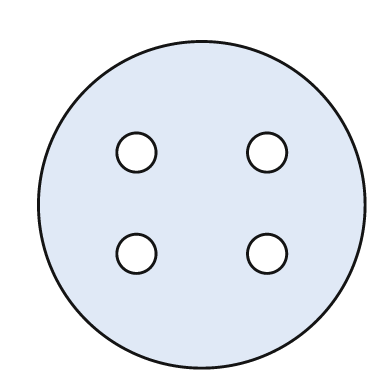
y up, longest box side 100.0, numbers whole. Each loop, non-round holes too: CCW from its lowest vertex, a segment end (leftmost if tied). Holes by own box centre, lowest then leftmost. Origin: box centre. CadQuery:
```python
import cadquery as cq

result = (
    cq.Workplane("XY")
    .moveTo(0.0, 0.0)
    .circle(50.0)
    .moveTo(-20.0, -15.0)
    .circle(6.0)
    .moveTo(20.0, -15.0)
    .circle(6.0)
    .moveTo(-20.0, 16.0)
    .circle(6.0)
    .moveTo(20.0, 16.0)
    .circle(6.0)
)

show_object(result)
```